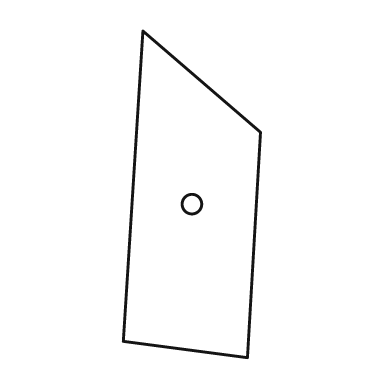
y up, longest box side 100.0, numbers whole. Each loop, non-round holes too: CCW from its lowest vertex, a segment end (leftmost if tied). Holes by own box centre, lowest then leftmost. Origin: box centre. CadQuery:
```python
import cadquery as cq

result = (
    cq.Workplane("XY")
    .moveTo(17.0, -50.0)
    .lineTo(21.0, 19.0)
    .lineTo(-15.0, 50.0)
    .lineTo(-21.0, -45.0)
    .close()
    .moveTo(0.0, -3.0)
    .circle(3.0)
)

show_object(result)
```